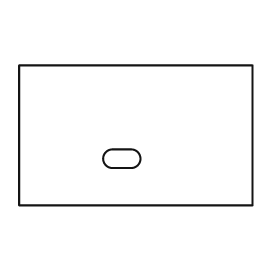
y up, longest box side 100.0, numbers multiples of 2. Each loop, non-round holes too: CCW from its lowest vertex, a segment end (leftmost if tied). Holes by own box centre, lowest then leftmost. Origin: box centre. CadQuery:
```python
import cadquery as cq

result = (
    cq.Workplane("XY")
    .moveTo(-50.0, -30.0)
    .lineTo(50.0, -30.0)
    .lineTo(50.0, 30.0)
    .lineTo(-50.0, 30.0)
    .close()
    .moveTo(-10.0, -14.0)
    .lineTo(-2.0, -14.0)
    .threePointArc((2.0, -10.0), (-2.0, -6.0))
    .lineTo(-10.0, -6.0)
    .threePointArc((-14.0, -10.0), (-10.0, -14.0))
    .close()
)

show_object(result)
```